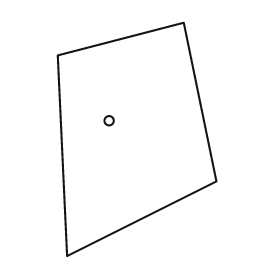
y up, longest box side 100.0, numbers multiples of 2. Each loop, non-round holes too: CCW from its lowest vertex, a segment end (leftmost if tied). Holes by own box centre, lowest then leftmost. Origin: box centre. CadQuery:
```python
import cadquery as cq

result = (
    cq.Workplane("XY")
    .moveTo(-30.0, -50.0)
    .lineTo(34.0, -18.0)
    .lineTo(20.0, 50.0)
    .lineTo(-34.0, 36.0)
    .close()
    .moveTo(-12.0, 8.0)
    .circle(2.0)
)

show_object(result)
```